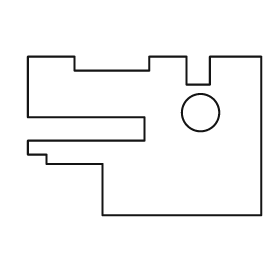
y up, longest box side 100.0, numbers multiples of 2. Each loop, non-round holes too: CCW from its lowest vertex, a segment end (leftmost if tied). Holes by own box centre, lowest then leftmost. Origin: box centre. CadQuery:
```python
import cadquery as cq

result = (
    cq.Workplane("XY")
    .moveTo(-18.0, -34.0)
    .lineTo(50.0, -34.0)
    .lineTo(50.0, 34.0)
    .lineTo(28.0, 34.0)
    .lineTo(28.0, 22.0)
    .lineTo(18.0, 22.0)
    .lineTo(18.0, 34.0)
    .lineTo(2.0, 34.0)
    .lineTo(2.0, 28.0)
    .lineTo(-30.0, 28.0)
    .lineTo(-30.0, 34.0)
    .lineTo(-50.0, 34.0)
    .lineTo(-50.0, 8.0)
    .lineTo(0.0, 8.0)
    .lineTo(0.0, -2.0)
    .lineTo(-50.0, -2.0)
    .lineTo(-50.0, -8.0)
    .lineTo(-42.0, -8.0)
    .lineTo(-42.0, -12.0)
    .lineTo(-18.0, -12.0)
    .close()
    .moveTo(24.0, 10.0)
    .circle(8.0)
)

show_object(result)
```